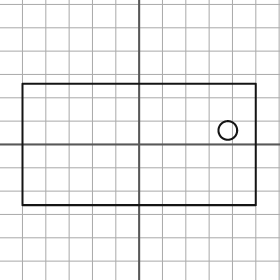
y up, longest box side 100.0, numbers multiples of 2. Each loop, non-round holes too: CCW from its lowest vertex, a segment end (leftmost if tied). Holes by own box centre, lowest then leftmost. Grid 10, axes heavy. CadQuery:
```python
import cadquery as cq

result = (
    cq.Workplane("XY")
    .moveTo(-50.0, -26.0)
    .lineTo(50.0, -26.0)
    .lineTo(50.0, 26.0)
    .lineTo(-50.0, 26.0)
    .close()
    .moveTo(38.0, 6.0)
    .circle(4.0)
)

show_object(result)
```